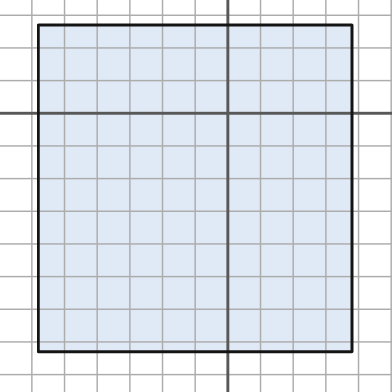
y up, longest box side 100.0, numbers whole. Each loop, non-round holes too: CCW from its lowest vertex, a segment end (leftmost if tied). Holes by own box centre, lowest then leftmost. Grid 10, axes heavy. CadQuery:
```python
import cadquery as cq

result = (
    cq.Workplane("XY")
    .moveTo(-58.0, -73.0)
    .lineTo(38.0, -73.0)
    .lineTo(38.0, 27.0)
    .lineTo(-58.0, 27.0)
    .close()
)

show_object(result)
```